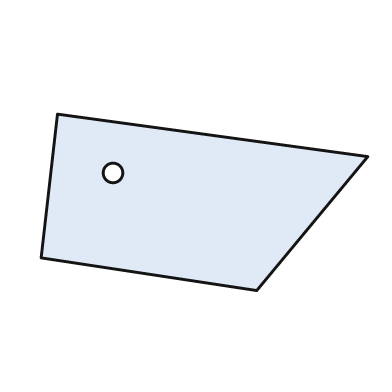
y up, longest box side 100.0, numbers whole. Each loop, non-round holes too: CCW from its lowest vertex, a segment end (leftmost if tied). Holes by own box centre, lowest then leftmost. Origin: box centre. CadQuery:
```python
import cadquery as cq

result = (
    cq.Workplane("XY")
    .moveTo(16.0, -27.0)
    .lineTo(50.0, 14.0)
    .lineTo(-45.0, 27.0)
    .lineTo(-50.0, -17.0)
    .close()
    .moveTo(-28.0, 9.0)
    .circle(3.0)
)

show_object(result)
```